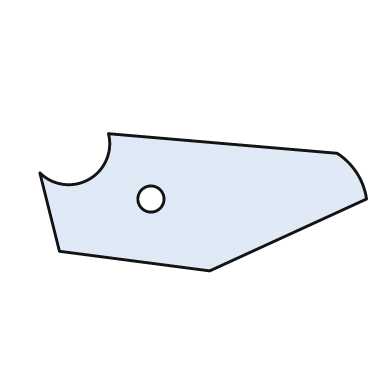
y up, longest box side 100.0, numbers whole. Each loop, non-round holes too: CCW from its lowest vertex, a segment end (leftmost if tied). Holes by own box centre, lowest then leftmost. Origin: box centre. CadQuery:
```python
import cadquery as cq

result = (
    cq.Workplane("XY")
    .moveTo(2.0, -21.0)
    .lineTo(50.0, 1.0)
    .threePointArc((47.0, 9.0), (41.0, 15.0))
    .lineTo(-29.0, 21.0)
    .threePointArc((-35.0, 7.0), (-50.0, 9.0))
    .lineTo(-44.0, -15.0)
    .close()
    .moveTo(-16.0, 1.0)
    .circle(4.0)
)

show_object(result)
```